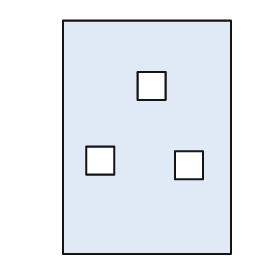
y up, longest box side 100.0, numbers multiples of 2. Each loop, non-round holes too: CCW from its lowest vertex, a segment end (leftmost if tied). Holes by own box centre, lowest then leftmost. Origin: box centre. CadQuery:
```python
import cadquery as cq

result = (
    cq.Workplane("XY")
    .moveTo(-36.0, -50.0)
    .lineTo(36.0, -50.0)
    .lineTo(36.0, 50.0)
    .lineTo(-36.0, 50.0)
    .close()
    .moveTo(12.0, -18.0)
    .lineTo(24.0, -18.0)
    .lineTo(24.0, -6.0)
    .lineTo(12.0, -6.0)
    .close()
    .moveTo(-26.0, -16.0)
    .lineTo(-14.0, -16.0)
    .lineTo(-14.0, -4.0)
    .lineTo(-26.0, -4.0)
    .close()
    .moveTo(-4.0, 16.0)
    .lineTo(8.0, 16.0)
    .lineTo(8.0, 28.0)
    .lineTo(-4.0, 28.0)
    .close()
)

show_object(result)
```